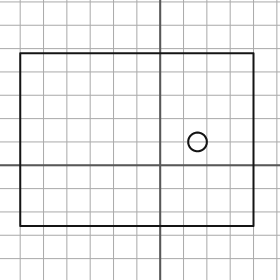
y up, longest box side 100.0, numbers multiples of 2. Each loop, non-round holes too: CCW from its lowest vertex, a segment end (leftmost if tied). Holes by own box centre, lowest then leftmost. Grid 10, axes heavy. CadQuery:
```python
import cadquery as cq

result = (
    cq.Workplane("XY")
    .moveTo(-60.0, -26.0)
    .lineTo(40.0, -26.0)
    .lineTo(40.0, 48.0)
    .lineTo(-60.0, 48.0)
    .close()
    .moveTo(16.0, 10.0)
    .circle(4.0)
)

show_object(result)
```